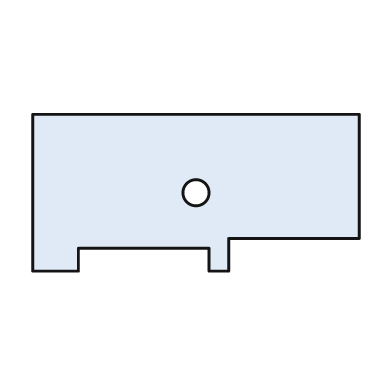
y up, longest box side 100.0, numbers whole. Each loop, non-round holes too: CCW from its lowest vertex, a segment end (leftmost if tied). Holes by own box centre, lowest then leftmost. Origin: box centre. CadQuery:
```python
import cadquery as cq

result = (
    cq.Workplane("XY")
    .moveTo(-50.0, -24.0)
    .lineTo(-36.0, -24.0)
    .lineTo(-36.0, -17.0)
    .lineTo(4.0, -17.0)
    .lineTo(4.0, -24.0)
    .lineTo(10.0, -24.0)
    .lineTo(10.0, -14.0)
    .lineTo(50.0, -14.0)
    .lineTo(50.0, 24.0)
    .lineTo(-50.0, 24.0)
    .close()
    .moveTo(0.0, 0.0)
    .circle(4.0)
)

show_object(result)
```